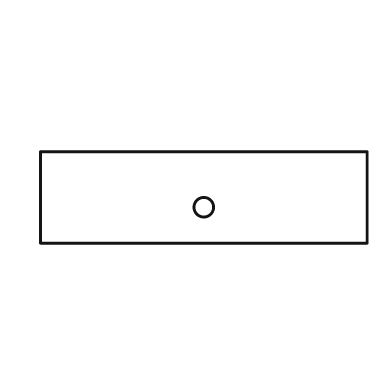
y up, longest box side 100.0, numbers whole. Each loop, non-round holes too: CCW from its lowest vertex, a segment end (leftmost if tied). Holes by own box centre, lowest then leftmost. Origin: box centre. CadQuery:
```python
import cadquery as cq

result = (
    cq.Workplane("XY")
    .moveTo(-50.0, -14.0)
    .lineTo(50.0, -14.0)
    .lineTo(50.0, 14.0)
    .lineTo(-50.0, 14.0)
    .close()
    .moveTo(0.0, -3.0)
    .circle(3.0)
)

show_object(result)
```